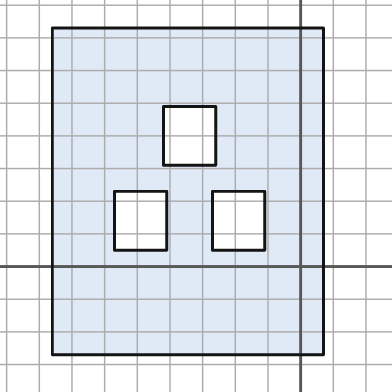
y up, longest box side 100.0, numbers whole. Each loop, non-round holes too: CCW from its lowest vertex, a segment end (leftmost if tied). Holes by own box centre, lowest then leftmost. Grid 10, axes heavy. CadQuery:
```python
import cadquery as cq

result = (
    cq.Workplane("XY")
    .moveTo(-76.0, -27.0)
    .lineTo(7.0, -27.0)
    .lineTo(7.0, 73.0)
    .lineTo(-76.0, 73.0)
    .close()
    .moveTo(-57.0, 5.0)
    .lineTo(-41.0, 5.0)
    .lineTo(-41.0, 23.0)
    .lineTo(-57.0, 23.0)
    .close()
    .moveTo(-27.0, 5.0)
    .lineTo(-11.0, 5.0)
    .lineTo(-11.0, 23.0)
    .lineTo(-27.0, 23.0)
    .close()
    .moveTo(-42.0, 31.0)
    .lineTo(-26.0, 31.0)
    .lineTo(-26.0, 49.0)
    .lineTo(-42.0, 49.0)
    .close()
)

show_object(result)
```